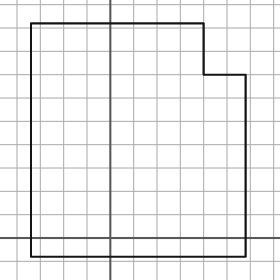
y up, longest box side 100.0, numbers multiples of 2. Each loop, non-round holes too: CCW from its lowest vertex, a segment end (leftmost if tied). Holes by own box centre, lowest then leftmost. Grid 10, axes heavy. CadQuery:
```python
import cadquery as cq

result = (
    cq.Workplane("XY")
    .moveTo(-34.0, -8.0)
    .lineTo(58.0, -8.0)
    .lineTo(58.0, 70.0)
    .lineTo(40.0, 70.0)
    .lineTo(40.0, 92.0)
    .lineTo(-34.0, 92.0)
    .close()
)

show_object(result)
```